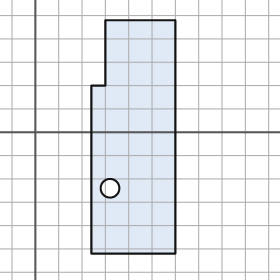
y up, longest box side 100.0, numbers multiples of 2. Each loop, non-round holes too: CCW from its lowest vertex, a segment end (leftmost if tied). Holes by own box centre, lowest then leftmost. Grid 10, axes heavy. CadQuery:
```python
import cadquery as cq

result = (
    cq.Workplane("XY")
    .moveTo(24.0, -52.0)
    .lineTo(60.0, -52.0)
    .lineTo(60.0, 48.0)
    .lineTo(30.0, 48.0)
    .lineTo(30.0, 20.0)
    .lineTo(24.0, 20.0)
    .close()
    .moveTo(32.0, -24.0)
    .circle(4.0)
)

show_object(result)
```